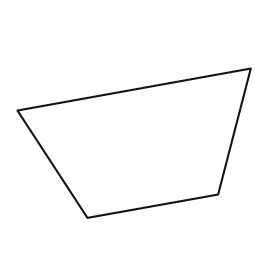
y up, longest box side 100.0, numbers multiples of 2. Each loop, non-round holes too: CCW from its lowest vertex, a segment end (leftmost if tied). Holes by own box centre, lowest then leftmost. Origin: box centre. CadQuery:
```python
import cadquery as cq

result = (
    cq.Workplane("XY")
    .moveTo(-20.0, -32.0)
    .lineTo(36.0, -22.0)
    .lineTo(50.0, 32.0)
    .lineTo(-50.0, 14.0)
    .close()
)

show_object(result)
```